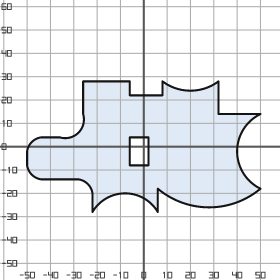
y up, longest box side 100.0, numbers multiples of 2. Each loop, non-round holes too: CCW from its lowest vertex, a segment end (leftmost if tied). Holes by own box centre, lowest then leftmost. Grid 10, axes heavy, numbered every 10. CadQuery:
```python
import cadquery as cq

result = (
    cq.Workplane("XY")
    .moveTo(-22.0, -28.0)
    .threePointArc((-8.0, -20.0), (6.0, -28.0))
    .lineTo(6.0, -18.0)
    .threePointArc((28.0, -26.0), (50.0, -18.0))
    .threePointArc((40.0, -2.0), (50.0, 14.0))
    .lineTo(32.0, 14.0)
    .lineTo(32.0, 28.0)
    .threePointArc((20.0, 24.0), (8.0, 28.0))
    .lineTo(8.0, 22.0)
    .lineTo(-6.0, 22.0)
    .lineTo(-6.0, 28.0)
    .lineTo(-26.0, 28.0)
    .lineTo(-26.0, 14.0)
    .threePointArc((-28.0, 6.0), (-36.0, 4.0))
    .lineTo(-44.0, 4.0)
    .threePointArc((-48.0, 2.0), (-50.0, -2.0))
    .lineTo(-50.0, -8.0)
    .threePointArc((-48.0, -12.0), (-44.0, -14.0))
    .lineTo(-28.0, -14.0)
    .threePointArc((-24.0, -16.0), (-22.0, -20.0))
    .close()
    .moveTo(-6.0, -8.0)
    .lineTo(2.0, -8.0)
    .lineTo(2.0, 4.0)
    .lineTo(-6.0, 4.0)
    .close()
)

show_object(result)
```